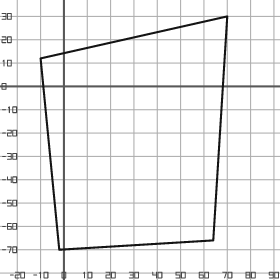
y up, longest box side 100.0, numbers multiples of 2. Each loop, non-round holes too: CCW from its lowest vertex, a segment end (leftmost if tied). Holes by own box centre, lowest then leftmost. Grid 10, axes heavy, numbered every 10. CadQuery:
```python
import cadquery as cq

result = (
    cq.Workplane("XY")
    .moveTo(-2.0, -70.0)
    .lineTo(64.0, -66.0)
    .lineTo(70.0, 30.0)
    .lineTo(-10.0, 12.0)
    .close()
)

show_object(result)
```